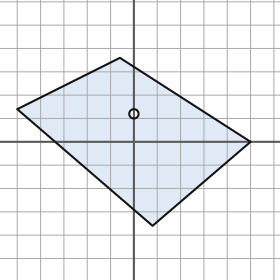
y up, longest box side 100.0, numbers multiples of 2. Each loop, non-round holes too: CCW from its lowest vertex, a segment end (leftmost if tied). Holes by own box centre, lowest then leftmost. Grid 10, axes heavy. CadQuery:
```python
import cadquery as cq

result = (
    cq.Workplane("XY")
    .moveTo(8.0, -36.0)
    .lineTo(50.0, 0.0)
    .lineTo(-6.0, 36.0)
    .lineTo(-50.0, 14.0)
    .close()
    .moveTo(0.0, 12.0)
    .circle(2.0)
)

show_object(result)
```